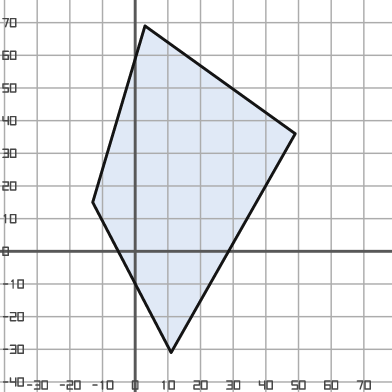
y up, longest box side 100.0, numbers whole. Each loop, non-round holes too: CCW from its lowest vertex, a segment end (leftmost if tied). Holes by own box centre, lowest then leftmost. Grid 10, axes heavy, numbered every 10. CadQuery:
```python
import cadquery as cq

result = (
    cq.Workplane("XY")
    .moveTo(11.0, -31.0)
    .lineTo(49.0, 36.0)
    .lineTo(3.0, 69.0)
    .lineTo(-13.0, 15.0)
    .close()
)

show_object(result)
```